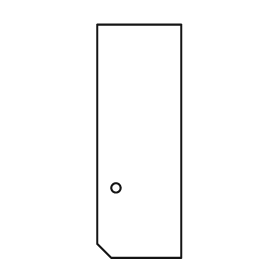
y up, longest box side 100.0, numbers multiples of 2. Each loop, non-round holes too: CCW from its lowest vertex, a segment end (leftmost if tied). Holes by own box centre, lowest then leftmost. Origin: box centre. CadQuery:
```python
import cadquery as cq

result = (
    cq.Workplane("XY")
    .moveTo(-12.0, -50.0)
    .lineTo(18.0, -50.0)
    .lineTo(18.0, 50.0)
    .lineTo(-18.0, 50.0)
    .lineTo(-18.0, -44.0)
    .close()
    .moveTo(-10.0, -20.0)
    .circle(2.0)
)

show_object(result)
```